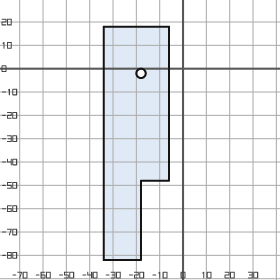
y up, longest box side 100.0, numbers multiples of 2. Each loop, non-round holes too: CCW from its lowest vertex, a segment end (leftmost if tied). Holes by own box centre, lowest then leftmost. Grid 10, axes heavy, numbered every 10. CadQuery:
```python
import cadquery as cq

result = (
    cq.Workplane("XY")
    .moveTo(-34.0, -82.0)
    .lineTo(-18.0, -82.0)
    .lineTo(-18.0, -48.0)
    .lineTo(-6.0, -48.0)
    .lineTo(-6.0, 18.0)
    .lineTo(-34.0, 18.0)
    .close()
    .moveTo(-18.0, -2.0)
    .circle(2.0)
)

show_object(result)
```